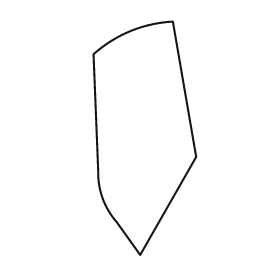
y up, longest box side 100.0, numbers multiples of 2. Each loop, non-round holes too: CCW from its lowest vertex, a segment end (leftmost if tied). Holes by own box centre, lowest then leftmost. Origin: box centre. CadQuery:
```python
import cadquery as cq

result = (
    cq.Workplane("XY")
    .moveTo(-2.0, -50.0)
    .lineTo(22.0, -8.0)
    .lineTo(12.0, 50.0)
    .threePointArc((-6.0, 46.0), (-22.0, 36.0))
    .lineTo(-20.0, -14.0)
    .threePointArc((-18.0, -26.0), (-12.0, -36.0))
    .close()
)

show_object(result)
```